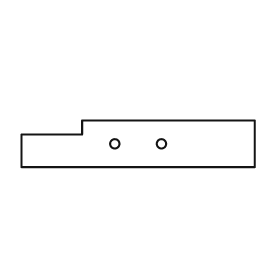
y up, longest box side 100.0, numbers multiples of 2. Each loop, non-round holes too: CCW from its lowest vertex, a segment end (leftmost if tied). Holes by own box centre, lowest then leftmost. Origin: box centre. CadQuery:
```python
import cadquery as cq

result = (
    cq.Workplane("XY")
    .moveTo(-50.0, -10.0)
    .lineTo(50.0, -10.0)
    .lineTo(50.0, 10.0)
    .lineTo(-24.0, 10.0)
    .lineTo(-24.0, 4.0)
    .lineTo(-50.0, 4.0)
    .close()
    .moveTo(-10.0, 0.0)
    .circle(2.0)
    .moveTo(10.0, 0.0)
    .circle(2.0)
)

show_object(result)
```